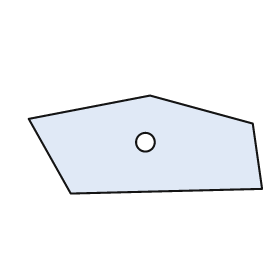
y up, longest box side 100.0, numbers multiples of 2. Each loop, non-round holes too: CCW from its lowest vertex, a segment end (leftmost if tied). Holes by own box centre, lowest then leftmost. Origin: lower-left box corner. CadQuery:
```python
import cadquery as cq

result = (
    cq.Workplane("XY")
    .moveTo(18.0, 0.0)
    .lineTo(100.0, 2.0)
    .lineTo(96.0, 30.0)
    .lineTo(52.0, 42.0)
    .lineTo(0.0, 32.0)
    .close()
    .moveTo(50.0, 22.0)
    .circle(4.0)
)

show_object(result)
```